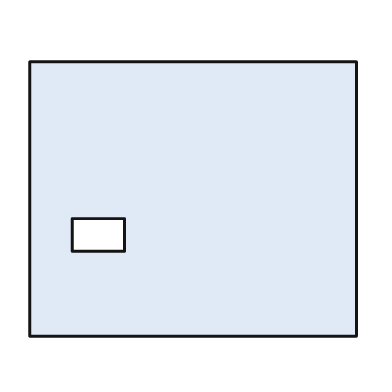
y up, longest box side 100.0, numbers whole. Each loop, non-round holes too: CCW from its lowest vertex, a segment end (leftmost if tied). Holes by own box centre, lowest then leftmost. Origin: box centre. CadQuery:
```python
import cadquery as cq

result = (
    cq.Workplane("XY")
    .moveTo(-50.0, -42.0)
    .lineTo(50.0, -42.0)
    .lineTo(50.0, 42.0)
    .lineTo(-50.0, 42.0)
    .close()
    .moveTo(-37.0, -16.0)
    .lineTo(-21.0, -16.0)
    .lineTo(-21.0, -6.0)
    .lineTo(-37.0, -6.0)
    .close()
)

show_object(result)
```